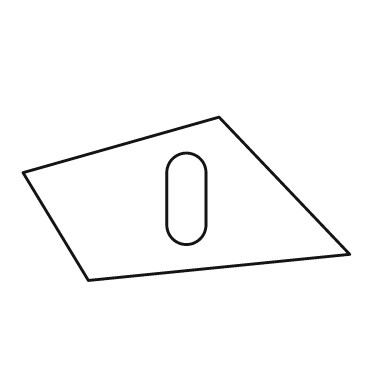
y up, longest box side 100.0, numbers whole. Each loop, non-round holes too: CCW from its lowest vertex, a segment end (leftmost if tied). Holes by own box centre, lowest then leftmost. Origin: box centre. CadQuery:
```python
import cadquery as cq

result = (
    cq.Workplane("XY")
    .moveTo(-30.0, -25.0)
    .lineTo(50.0, -17.0)
    .lineTo(10.0, 25.0)
    .lineTo(-50.0, 8.0)
    .close()
    .moveTo(-6.0, -8.0)
    .threePointArc((0.0, -14.0), (6.0, -8.0))
    .lineTo(6.0, 8.0)
    .threePointArc((0.0, 14.0), (-6.0, 8.0))
    .close()
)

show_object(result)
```